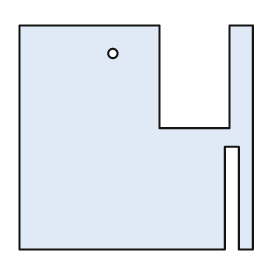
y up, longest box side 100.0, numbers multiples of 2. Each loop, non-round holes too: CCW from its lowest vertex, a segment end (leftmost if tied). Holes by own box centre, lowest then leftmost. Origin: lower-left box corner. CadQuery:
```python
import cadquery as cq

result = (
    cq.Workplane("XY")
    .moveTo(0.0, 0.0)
    .lineTo(88.0, 0.0)
    .lineTo(88.0, 44.0)
    .lineTo(94.0, 44.0)
    .lineTo(94.0, 0.0)
    .lineTo(100.0, 0.0)
    .lineTo(100.0, 96.0)
    .lineTo(90.0, 96.0)
    .lineTo(90.0, 52.0)
    .lineTo(60.0, 52.0)
    .lineTo(60.0, 96.0)
    .lineTo(0.0, 96.0)
    .close()
    .moveTo(40.0, 84.0)
    .circle(2.0)
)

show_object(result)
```